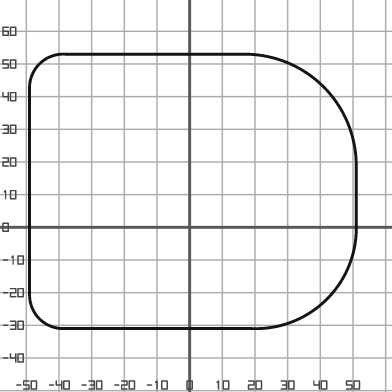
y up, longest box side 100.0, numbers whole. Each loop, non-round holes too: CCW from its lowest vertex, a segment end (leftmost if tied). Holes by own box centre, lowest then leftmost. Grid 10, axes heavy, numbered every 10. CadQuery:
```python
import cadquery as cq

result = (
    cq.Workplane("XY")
    .moveTo(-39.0, -31.0)
    .lineTo(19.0, -31.0)
    .threePointArc((42.0, -22.0), (51.0, 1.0))
    .lineTo(51.0, 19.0)
    .threePointArc((41.0, 43.0), (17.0, 53.0))
    .lineTo(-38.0, 53.0)
    .threePointArc((-46.0, 50.0), (-49.0, 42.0))
    .lineTo(-49.0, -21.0)
    .threePointArc((-46.0, -28.0), (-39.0, -31.0))
    .close()
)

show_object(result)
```